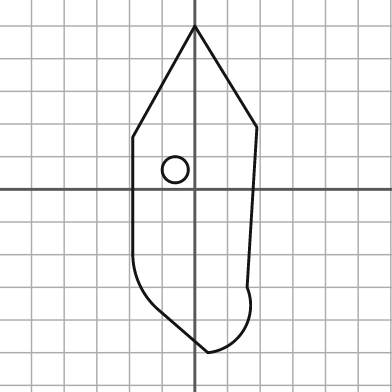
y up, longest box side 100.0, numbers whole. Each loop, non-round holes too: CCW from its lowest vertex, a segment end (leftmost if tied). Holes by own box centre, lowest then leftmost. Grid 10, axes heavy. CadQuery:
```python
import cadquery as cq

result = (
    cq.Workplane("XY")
    .moveTo(4.0, -50.0)
    .threePointArc((15.0, -43.0), (16.0, -30.0))
    .lineTo(19.0, 19.0)
    .lineTo(0.0, 50.0)
    .lineTo(-19.0, 16.0)
    .lineTo(-19.0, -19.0)
    .threePointArc((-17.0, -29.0), (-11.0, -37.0))
    .close()
    .moveTo(-6.0, 6.0)
    .circle(4.0)
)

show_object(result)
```